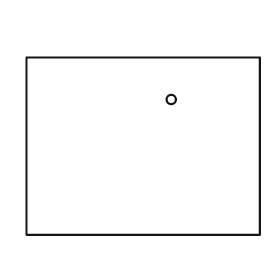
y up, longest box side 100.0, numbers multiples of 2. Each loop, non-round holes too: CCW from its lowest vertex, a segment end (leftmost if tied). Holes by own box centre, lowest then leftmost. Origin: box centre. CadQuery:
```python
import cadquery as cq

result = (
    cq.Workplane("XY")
    .moveTo(-50.0, -38.0)
    .lineTo(50.0, -38.0)
    .lineTo(50.0, 38.0)
    .lineTo(-50.0, 38.0)
    .close()
    .moveTo(12.0, 20.0)
    .circle(2.0)
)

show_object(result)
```